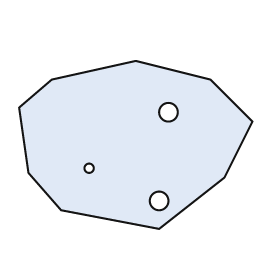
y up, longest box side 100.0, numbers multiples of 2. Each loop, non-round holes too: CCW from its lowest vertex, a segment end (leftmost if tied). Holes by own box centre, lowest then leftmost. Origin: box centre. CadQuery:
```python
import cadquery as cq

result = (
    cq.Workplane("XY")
    .moveTo(10.0, -36.0)
    .lineTo(38.0, -14.0)
    .lineTo(50.0, 10.0)
    .lineTo(32.0, 28.0)
    .lineTo(0.0, 36.0)
    .lineTo(-36.0, 28.0)
    .lineTo(-50.0, 16.0)
    .lineTo(-46.0, -12.0)
    .lineTo(-32.0, -28.0)
    .close()
    .moveTo(10.0, -24.0)
    .circle(4.0)
    .moveTo(-20.0, -10.0)
    .circle(2.0)
    .moveTo(14.0, 14.0)
    .circle(4.0)
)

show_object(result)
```